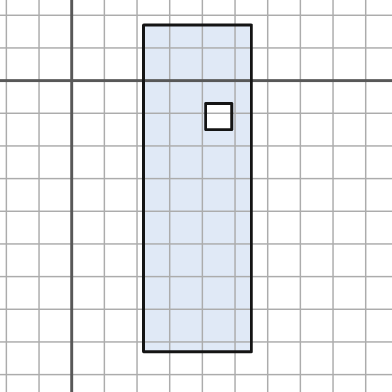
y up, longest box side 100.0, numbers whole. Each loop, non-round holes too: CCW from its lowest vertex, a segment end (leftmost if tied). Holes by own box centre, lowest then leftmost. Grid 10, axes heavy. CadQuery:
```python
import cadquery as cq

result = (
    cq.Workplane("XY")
    .moveTo(22.0, -83.0)
    .lineTo(55.0, -83.0)
    .lineTo(55.0, 17.0)
    .lineTo(22.0, 17.0)
    .close()
    .moveTo(41.0, -15.0)
    .lineTo(49.0, -15.0)
    .lineTo(49.0, -7.0)
    .lineTo(41.0, -7.0)
    .close()
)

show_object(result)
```